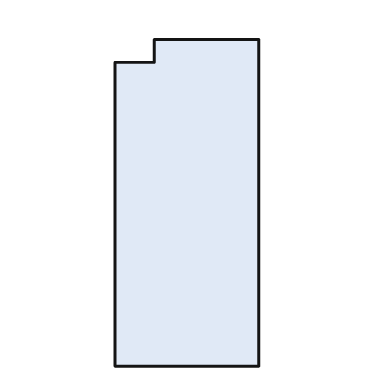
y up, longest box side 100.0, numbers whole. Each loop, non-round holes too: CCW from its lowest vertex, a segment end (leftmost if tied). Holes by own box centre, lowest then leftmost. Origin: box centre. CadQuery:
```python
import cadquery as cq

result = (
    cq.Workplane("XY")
    .moveTo(-22.0, -50.0)
    .lineTo(22.0, -50.0)
    .lineTo(22.0, 50.0)
    .lineTo(-10.0, 50.0)
    .lineTo(-10.0, 43.0)
    .lineTo(-22.0, 43.0)
    .close()
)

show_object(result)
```